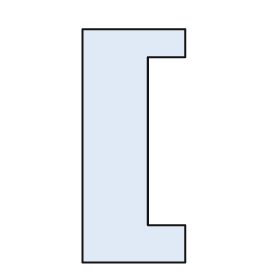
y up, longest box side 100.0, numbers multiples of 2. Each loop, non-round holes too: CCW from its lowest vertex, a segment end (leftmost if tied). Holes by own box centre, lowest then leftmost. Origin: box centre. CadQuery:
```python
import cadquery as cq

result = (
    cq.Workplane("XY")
    .moveTo(-22.0, -50.0)
    .lineTo(22.0, -50.0)
    .lineTo(22.0, -34.0)
    .lineTo(6.0, -34.0)
    .lineTo(6.0, 38.0)
    .lineTo(22.0, 38.0)
    .lineTo(22.0, 50.0)
    .lineTo(-22.0, 50.0)
    .close()
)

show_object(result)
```